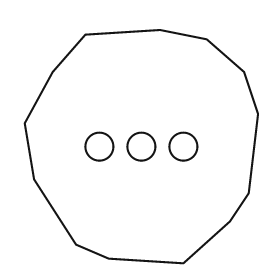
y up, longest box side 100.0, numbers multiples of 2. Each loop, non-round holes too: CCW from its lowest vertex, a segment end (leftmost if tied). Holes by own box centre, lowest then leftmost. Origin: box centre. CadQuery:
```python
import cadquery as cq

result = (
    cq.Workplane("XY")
    .moveTo(18.0, -50.0)
    .lineTo(38.0, -32.0)
    .lineTo(46.0, -20.0)
    .lineTo(50.0, 14.0)
    .lineTo(44.0, 32.0)
    .lineTo(28.0, 46.0)
    .lineTo(8.0, 50.0)
    .lineTo(-24.0, 48.0)
    .lineTo(-38.0, 32.0)
    .lineTo(-50.0, 10.0)
    .lineTo(-46.0, -14.0)
    .lineTo(-28.0, -42.0)
    .lineTo(-14.0, -48.0)
    .close()
    .moveTo(-18.0, 0.0)
    .circle(6.0)
    .moveTo(0.0, 0.0)
    .circle(6.0)
    .moveTo(18.0, 0.0)
    .circle(6.0)
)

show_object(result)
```